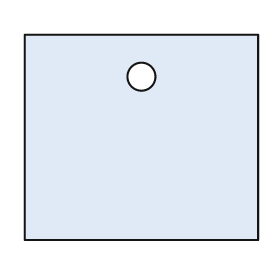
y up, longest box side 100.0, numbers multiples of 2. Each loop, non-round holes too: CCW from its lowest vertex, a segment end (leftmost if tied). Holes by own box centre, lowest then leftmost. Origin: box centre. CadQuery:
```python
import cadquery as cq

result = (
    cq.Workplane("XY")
    .moveTo(-50.0, -44.0)
    .lineTo(50.0, -44.0)
    .lineTo(50.0, 44.0)
    .lineTo(-50.0, 44.0)
    .close()
    .moveTo(0.0, 26.0)
    .circle(6.0)
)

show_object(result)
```